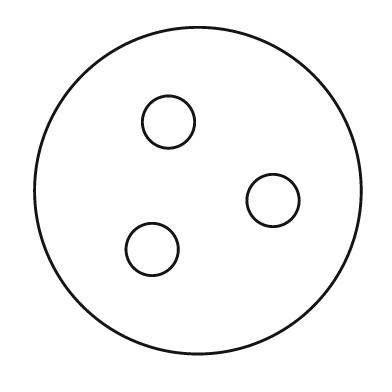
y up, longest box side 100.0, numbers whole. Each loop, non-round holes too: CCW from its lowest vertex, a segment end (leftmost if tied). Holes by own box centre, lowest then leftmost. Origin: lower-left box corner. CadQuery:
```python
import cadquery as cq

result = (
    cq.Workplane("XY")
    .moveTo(50.0, 50.0)
    .circle(50.0)
    .moveTo(36.0, 32.0)
    .circle(8.0)
    .moveTo(73.0, 47.0)
    .circle(8.0)
    .moveTo(41.0, 71.0)
    .circle(8.0)
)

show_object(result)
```